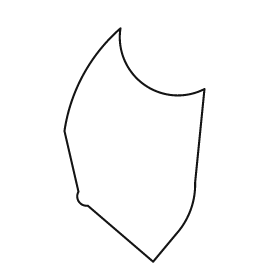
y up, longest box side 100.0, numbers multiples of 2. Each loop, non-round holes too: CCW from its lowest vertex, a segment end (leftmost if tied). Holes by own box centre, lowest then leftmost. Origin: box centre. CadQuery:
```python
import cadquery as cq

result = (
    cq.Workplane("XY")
    .moveTo(8.0, -50.0)
    .lineTo(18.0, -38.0)
    .threePointArc((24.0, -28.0), (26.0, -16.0))
    .lineTo(30.0, 24.0)
    .threePointArc((4.0, 26.0), (-6.0, 50.0))
    .threePointArc((-22.0, 30.0), (-30.0, 6.0))
    .lineTo(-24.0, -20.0)
    .threePointArc((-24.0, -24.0), (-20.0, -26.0))
    .close()
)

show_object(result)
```